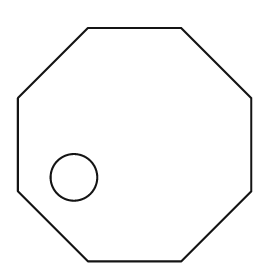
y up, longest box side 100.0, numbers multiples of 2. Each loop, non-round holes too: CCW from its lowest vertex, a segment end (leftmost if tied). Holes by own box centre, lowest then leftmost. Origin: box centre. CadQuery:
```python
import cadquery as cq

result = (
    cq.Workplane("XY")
    .moveTo(-20.0, -50.0)
    .lineTo(20.0, -50.0)
    .lineTo(50.0, -20.0)
    .lineTo(50.0, 20.0)
    .lineTo(20.0, 50.0)
    .lineTo(-20.0, 50.0)
    .lineTo(-50.0, 20.0)
    .lineTo(-50.0, -20.0)
    .close()
    .moveTo(-26.0, -14.0)
    .circle(10.0)
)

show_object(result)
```